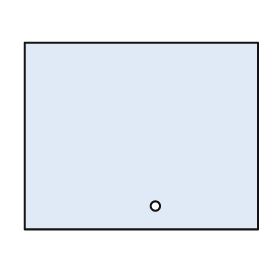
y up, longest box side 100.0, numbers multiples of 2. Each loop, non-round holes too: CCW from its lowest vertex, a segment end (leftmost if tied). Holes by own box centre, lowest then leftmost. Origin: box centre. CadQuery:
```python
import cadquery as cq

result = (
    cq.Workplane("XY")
    .moveTo(-50.0, -40.0)
    .lineTo(50.0, -40.0)
    .lineTo(50.0, 40.0)
    .lineTo(-50.0, 40.0)
    .close()
    .moveTo(6.0, -30.0)
    .circle(2.0)
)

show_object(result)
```